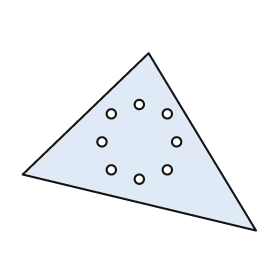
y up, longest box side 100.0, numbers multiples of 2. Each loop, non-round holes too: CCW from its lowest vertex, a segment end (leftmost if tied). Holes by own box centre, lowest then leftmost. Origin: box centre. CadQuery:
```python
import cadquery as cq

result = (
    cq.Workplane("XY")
    .moveTo(50.0, -38.0)
    .lineTo(4.0, 38.0)
    .lineTo(-50.0, -14.0)
    .close()
    .moveTo(0.0, -16.0)
    .circle(2.0)
    .moveTo(-12.0, -12.0)
    .circle(2.0)
    .moveTo(12.0, -12.0)
    .circle(2.0)
    .moveTo(-16.0, 0.0)
    .circle(2.0)
    .moveTo(16.0, 0.0)
    .circle(2.0)
    .moveTo(-12.0, 12.0)
    .circle(2.0)
    .moveTo(12.0, 12.0)
    .circle(2.0)
    .moveTo(0.0, 16.0)
    .circle(2.0)
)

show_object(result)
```